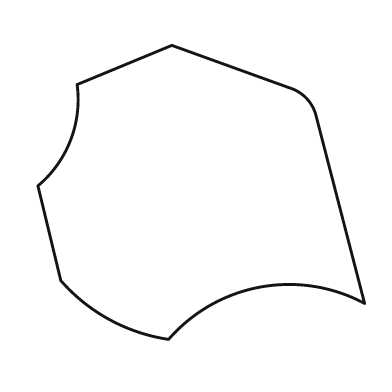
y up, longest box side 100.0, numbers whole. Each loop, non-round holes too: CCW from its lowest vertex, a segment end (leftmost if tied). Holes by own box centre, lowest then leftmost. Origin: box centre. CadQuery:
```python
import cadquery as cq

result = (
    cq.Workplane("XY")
    .moveTo(-10.0, -45.0)
    .threePointArc((18.0, -29.0), (50.0, -34.0))
    .lineTo(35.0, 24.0)
    .threePointArc((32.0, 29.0), (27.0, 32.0))
    .lineTo(-9.0, 45.0)
    .lineTo(-38.0, 33.0)
    .threePointArc((-40.0, 16.0), (-50.0, 2.0))
    .lineTo(-43.0, -27.0)
    .threePointArc((-28.0, -39.0), (-10.0, -45.0))
    .close()
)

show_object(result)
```